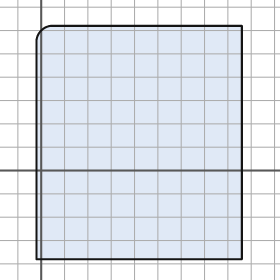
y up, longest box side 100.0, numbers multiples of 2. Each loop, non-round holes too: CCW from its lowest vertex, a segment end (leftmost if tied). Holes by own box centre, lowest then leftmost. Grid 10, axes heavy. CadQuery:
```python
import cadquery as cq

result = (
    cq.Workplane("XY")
    .moveTo(-2.0, -38.0)
    .lineTo(86.0, -38.0)
    .lineTo(86.0, 62.0)
    .lineTo(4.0, 62.0)
    .threePointArc((0.0, 60.0), (-2.0, 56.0))
    .close()
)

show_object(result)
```